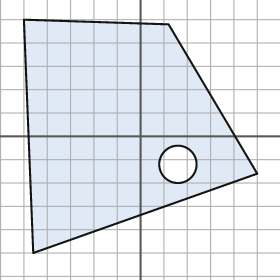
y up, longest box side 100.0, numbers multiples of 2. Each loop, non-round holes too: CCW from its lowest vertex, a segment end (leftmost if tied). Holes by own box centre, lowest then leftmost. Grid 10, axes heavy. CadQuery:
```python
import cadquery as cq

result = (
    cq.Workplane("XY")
    .moveTo(-46.0, -50.0)
    .lineTo(50.0, -16.0)
    .lineTo(12.0, 48.0)
    .lineTo(-50.0, 50.0)
    .close()
    .moveTo(16.0, -12.0)
    .circle(8.0)
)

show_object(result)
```